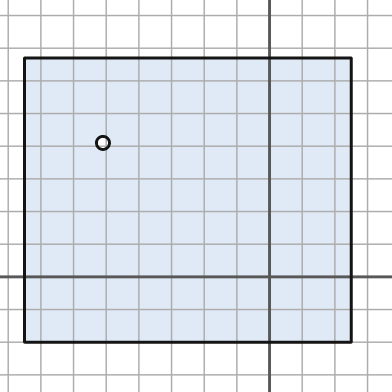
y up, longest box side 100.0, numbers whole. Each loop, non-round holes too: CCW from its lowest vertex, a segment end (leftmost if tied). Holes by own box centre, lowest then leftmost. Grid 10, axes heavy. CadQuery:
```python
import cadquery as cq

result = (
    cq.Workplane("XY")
    .moveTo(-75.0, -20.0)
    .lineTo(25.0, -20.0)
    .lineTo(25.0, 67.0)
    .lineTo(-75.0, 67.0)
    .close()
    .moveTo(-51.0, 41.0)
    .circle(2.0)
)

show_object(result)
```